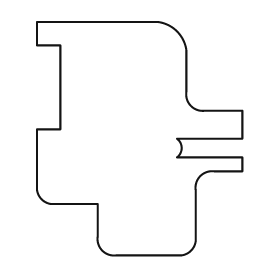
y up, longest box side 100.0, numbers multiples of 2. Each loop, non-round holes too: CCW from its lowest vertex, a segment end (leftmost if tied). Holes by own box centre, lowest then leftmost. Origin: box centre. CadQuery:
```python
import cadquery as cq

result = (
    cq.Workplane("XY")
    .moveTo(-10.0, -50.0)
    .lineTo(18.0, -50.0)
    .threePointArc((22.0, -48.0), (24.0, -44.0))
    .lineTo(24.0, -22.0)
    .threePointArc((26.0, -16.0), (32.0, -14.0))
    .lineTo(44.0, -14.0)
    .lineTo(44.0, -8.0)
    .lineTo(16.0, -8.0)
    .threePointArc((18.0, -4.0), (16.0, 0.0))
    .lineTo(44.0, 0.0)
    .lineTo(44.0, 12.0)
    .lineTo(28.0, 12.0)
    .threePointArc((22.0, 14.0), (20.0, 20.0))
    .lineTo(20.0, 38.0)
    .threePointArc((16.0, 46.0), (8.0, 50.0))
    .lineTo(-44.0, 50.0)
    .lineTo(-44.0, 40.0)
    .lineTo(-34.0, 40.0)
    .lineTo(-34.0, 4.0)
    .lineTo(-44.0, 4.0)
    .lineTo(-44.0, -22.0)
    .threePointArc((-42.0, -26.0), (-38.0, -28.0))
    .lineTo(-18.0, -28.0)
    .lineTo(-18.0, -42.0)
    .threePointArc((-16.0, -48.0), (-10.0, -50.0))
    .close()
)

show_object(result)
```